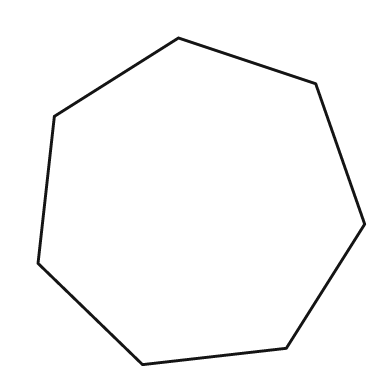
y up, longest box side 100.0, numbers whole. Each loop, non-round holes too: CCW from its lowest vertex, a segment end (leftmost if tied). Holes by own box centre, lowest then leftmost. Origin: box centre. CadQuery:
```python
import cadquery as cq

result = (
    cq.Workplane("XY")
    .moveTo(-18.0, -50.0)
    .lineTo(26.0, -45.0)
    .lineTo(50.0, -7.0)
    .lineTo(35.0, 36.0)
    .lineTo(-7.0, 50.0)
    .lineTo(-45.0, 26.0)
    .lineTo(-50.0, -19.0)
    .close()
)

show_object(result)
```